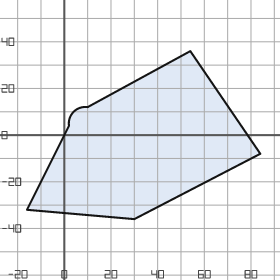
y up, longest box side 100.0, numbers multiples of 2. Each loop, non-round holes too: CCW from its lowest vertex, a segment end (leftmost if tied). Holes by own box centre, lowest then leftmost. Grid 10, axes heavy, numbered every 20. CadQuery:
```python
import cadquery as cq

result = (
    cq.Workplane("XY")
    .moveTo(30.0, -36.0)
    .lineTo(84.0, -8.0)
    .lineTo(54.0, 36.0)
    .lineTo(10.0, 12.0)
    .threePointArc((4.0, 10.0), (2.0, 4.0))
    .lineTo(-16.0, -32.0)
    .close()
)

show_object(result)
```